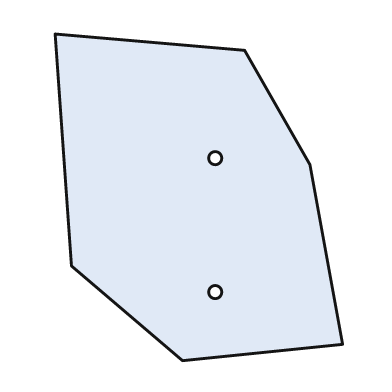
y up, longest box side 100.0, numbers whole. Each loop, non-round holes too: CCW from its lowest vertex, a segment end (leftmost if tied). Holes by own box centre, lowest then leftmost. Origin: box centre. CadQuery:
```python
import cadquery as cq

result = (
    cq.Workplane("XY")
    .moveTo(-5.0, -50.0)
    .lineTo(44.0, -45.0)
    .lineTo(34.0, 10.0)
    .lineTo(14.0, 45.0)
    .lineTo(-44.0, 50.0)
    .lineTo(-39.0, -21.0)
    .close()
    .moveTo(5.0, -29.0)
    .circle(2.0)
    .moveTo(5.0, 12.0)
    .circle(2.0)
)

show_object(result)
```